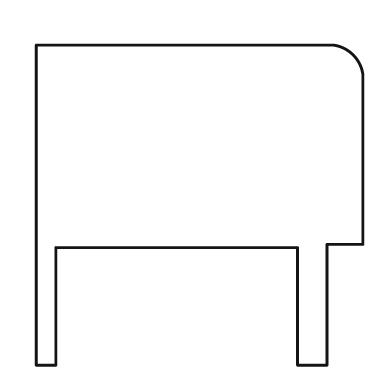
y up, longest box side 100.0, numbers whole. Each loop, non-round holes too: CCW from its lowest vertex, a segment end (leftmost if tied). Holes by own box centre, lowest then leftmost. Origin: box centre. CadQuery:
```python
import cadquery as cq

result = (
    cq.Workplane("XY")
    .moveTo(-50.0, -49.0)
    .lineTo(-44.0, -49.0)
    .lineTo(-44.0, -13.0)
    .lineTo(30.0, -13.0)
    .lineTo(30.0, -49.0)
    .lineTo(39.0, -49.0)
    .lineTo(39.0, -12.0)
    .lineTo(50.0, -12.0)
    .lineTo(50.0, 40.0)
    .threePointArc((47.0, 46.0), (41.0, 49.0))
    .lineTo(-50.0, 49.0)
    .close()
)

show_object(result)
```